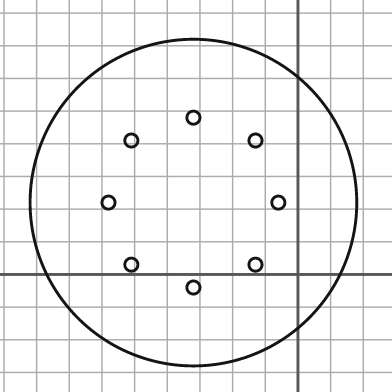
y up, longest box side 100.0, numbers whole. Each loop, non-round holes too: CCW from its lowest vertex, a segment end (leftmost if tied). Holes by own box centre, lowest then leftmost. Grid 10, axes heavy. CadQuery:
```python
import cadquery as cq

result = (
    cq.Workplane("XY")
    .moveTo(-32.0, 22.0)
    .circle(50.0)
    .moveTo(-32.0, -4.0)
    .circle(2.0)
    .moveTo(-51.0, 3.0)
    .circle(2.0)
    .moveTo(-13.0, 3.0)
    .circle(2.0)
    .moveTo(-58.0, 22.0)
    .circle(2.0)
    .moveTo(-6.0, 22.0)
    .circle(2.0)
    .moveTo(-51.0, 41.0)
    .circle(2.0)
    .moveTo(-13.0, 41.0)
    .circle(2.0)
    .moveTo(-32.0, 48.0)
    .circle(2.0)
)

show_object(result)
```